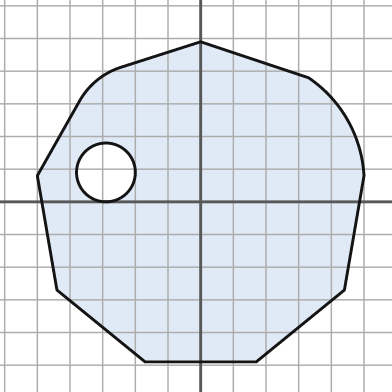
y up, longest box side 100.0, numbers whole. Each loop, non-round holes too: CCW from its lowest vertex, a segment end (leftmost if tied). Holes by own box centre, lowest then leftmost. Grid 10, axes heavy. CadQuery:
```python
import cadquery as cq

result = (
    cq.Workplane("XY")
    .moveTo(-17.0, -49.0)
    .lineTo(17.0, -49.0)
    .lineTo(44.0, -27.0)
    .lineTo(50.0, 8.0)
    .threePointArc((45.0, 25.0), (33.0, 38.0))
    .lineTo(0.0, 49.0)
    .lineTo(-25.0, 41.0)
    .threePointArc((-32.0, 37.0), (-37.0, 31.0))
    .lineTo(-50.0, 8.0)
    .lineTo(-44.0, -27.0)
    .close()
    .moveTo(-29.0, 9.0)
    .circle(9.0)
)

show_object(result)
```